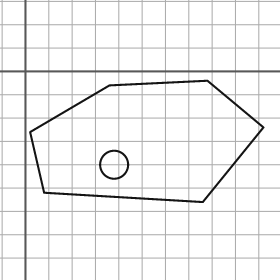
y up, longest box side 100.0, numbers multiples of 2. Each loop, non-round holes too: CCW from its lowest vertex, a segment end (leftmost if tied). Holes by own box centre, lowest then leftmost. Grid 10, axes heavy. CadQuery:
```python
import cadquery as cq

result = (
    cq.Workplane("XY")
    .moveTo(76.0, -56.0)
    .lineTo(102.0, -24.0)
    .lineTo(78.0, -4.0)
    .lineTo(36.0, -6.0)
    .lineTo(2.0, -26.0)
    .lineTo(8.0, -52.0)
    .close()
    .moveTo(38.0, -40.0)
    .circle(6.0)
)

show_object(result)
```